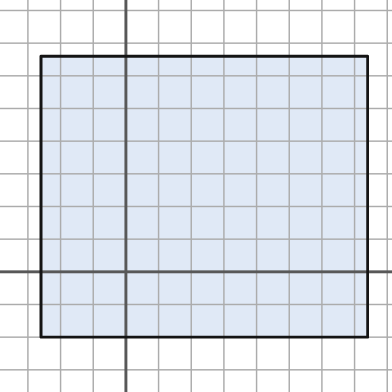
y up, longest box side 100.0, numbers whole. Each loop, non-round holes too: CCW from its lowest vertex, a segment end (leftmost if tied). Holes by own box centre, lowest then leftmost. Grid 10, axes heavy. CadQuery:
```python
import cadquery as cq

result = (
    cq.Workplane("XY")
    .moveTo(-26.0, -20.0)
    .lineTo(74.0, -20.0)
    .lineTo(74.0, 66.0)
    .lineTo(-26.0, 66.0)
    .close()
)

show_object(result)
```